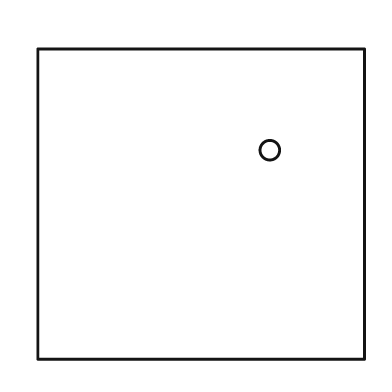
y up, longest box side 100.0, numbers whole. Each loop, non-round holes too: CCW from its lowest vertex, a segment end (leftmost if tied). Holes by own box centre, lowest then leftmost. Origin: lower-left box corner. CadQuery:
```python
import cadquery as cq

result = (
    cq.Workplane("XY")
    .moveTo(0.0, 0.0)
    .lineTo(100.0, 0.0)
    .lineTo(100.0, 95.0)
    .lineTo(0.0, 95.0)
    .close()
    .moveTo(71.0, 64.0)
    .circle(3.0)
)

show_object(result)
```